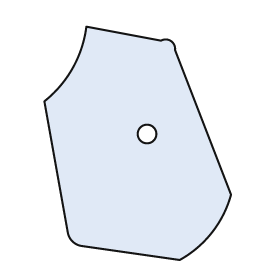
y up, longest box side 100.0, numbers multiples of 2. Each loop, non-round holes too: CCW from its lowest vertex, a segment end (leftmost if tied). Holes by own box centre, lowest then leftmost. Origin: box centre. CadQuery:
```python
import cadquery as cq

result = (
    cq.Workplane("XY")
    .moveTo(18.0, -50.0)
    .threePointArc((32.0, -38.0), (40.0, -22.0))
    .lineTo(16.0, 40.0)
    .threePointArc((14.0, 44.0), (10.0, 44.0))
    .lineTo(-22.0, 50.0)
    .threePointArc((-28.0, 32.0), (-40.0, 18.0))
    .lineTo(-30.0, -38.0)
    .threePointArc((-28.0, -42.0), (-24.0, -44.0))
    .close()
    .moveTo(4.0, 4.0)
    .circle(4.0)
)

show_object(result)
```